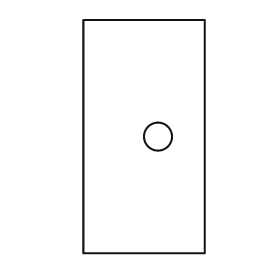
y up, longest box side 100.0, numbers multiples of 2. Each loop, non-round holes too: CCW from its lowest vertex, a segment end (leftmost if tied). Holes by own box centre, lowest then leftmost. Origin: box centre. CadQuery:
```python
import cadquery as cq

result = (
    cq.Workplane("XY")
    .moveTo(-26.0, -50.0)
    .lineTo(26.0, -50.0)
    .lineTo(26.0, 50.0)
    .lineTo(-26.0, 50.0)
    .close()
    .moveTo(6.0, 0.0)
    .circle(6.0)
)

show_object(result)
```